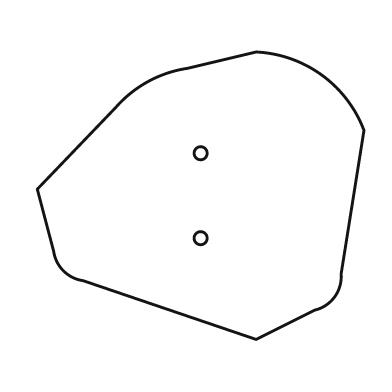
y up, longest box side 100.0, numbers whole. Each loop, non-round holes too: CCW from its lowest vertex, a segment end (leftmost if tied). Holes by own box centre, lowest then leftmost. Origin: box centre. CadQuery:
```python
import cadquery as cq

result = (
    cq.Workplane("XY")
    .moveTo(17.0, -44.0)
    .lineTo(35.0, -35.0)
    .threePointArc((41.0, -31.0), (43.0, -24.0))
    .lineTo(50.0, 20.0)
    .threePointArc((37.0, 37.0), (17.0, 44.0))
    .lineTo(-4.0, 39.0)
    .threePointArc((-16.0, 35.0), (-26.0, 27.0))
    .lineTo(-50.0, 2.0)
    .lineTo(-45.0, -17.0)
    .threePointArc((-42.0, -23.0), (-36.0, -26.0))
    .close()
    .moveTo(0.0, -13.0)
    .circle(2.0)
    .moveTo(0.0, 13.0)
    .circle(2.0)
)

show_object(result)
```